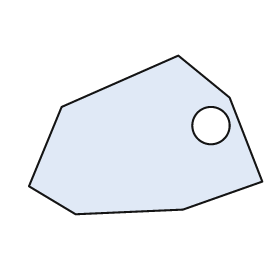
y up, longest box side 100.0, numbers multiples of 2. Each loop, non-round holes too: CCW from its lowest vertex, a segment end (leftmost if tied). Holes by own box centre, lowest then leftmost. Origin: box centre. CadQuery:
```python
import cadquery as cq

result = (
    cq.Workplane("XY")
    .moveTo(-30.0, -34.0)
    .lineTo(16.0, -32.0)
    .lineTo(50.0, -20.0)
    .lineTo(36.0, 16.0)
    .lineTo(14.0, 34.0)
    .lineTo(-36.0, 12.0)
    .lineTo(-50.0, -22.0)
    .close()
    .moveTo(28.0, 4.0)
    .circle(8.0)
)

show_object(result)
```